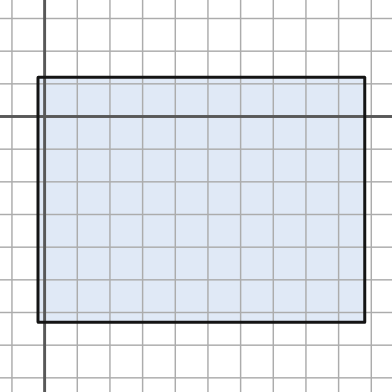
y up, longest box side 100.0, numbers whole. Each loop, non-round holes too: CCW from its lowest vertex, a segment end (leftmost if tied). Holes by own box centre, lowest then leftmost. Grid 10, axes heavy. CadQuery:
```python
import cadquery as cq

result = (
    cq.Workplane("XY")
    .moveTo(-2.0, -63.0)
    .lineTo(98.0, -63.0)
    .lineTo(98.0, 12.0)
    .lineTo(-2.0, 12.0)
    .close()
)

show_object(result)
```